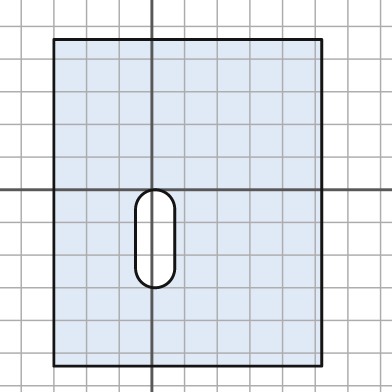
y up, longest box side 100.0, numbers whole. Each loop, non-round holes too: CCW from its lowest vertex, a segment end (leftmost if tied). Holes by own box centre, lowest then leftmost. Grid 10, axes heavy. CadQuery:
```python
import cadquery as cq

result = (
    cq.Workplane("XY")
    .moveTo(-30.0, -54.0)
    .lineTo(52.0, -54.0)
    .lineTo(52.0, 46.0)
    .lineTo(-30.0, 46.0)
    .close()
    .moveTo(-5.0, -24.0)
    .threePointArc((1.0, -30.0), (7.0, -24.0))
    .lineTo(7.0, -6.0)
    .threePointArc((1.0, 0.0), (-5.0, -6.0))
    .close()
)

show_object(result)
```